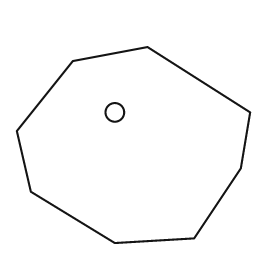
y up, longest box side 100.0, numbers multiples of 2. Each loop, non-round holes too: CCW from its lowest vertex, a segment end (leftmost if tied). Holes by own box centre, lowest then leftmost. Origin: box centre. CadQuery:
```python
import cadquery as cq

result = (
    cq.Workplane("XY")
    .moveTo(-8.0, -42.0)
    .lineTo(26.0, -40.0)
    .lineTo(46.0, -10.0)
    .lineTo(50.0, 14.0)
    .lineTo(6.0, 42.0)
    .lineTo(-26.0, 36.0)
    .lineTo(-50.0, 6.0)
    .lineTo(-44.0, -20.0)
    .close()
    .moveTo(-8.0, 14.0)
    .circle(4.0)
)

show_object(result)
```